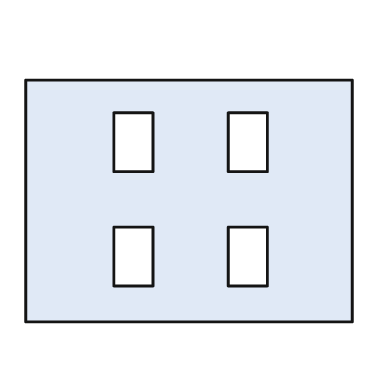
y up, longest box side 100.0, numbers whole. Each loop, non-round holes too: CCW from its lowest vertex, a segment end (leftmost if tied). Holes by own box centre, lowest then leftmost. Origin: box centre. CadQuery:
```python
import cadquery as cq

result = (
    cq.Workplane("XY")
    .moveTo(-50.0, -37.0)
    .lineTo(50.0, -37.0)
    .lineTo(50.0, 37.0)
    .lineTo(-50.0, 37.0)
    .close()
    .moveTo(-23.0, -26.0)
    .lineTo(-11.0, -26.0)
    .lineTo(-11.0, -8.0)
    .lineTo(-23.0, -8.0)
    .close()
    .moveTo(12.0, -26.0)
    .lineTo(24.0, -26.0)
    .lineTo(24.0, -8.0)
    .lineTo(12.0, -8.0)
    .close()
    .moveTo(-23.0, 9.0)
    .lineTo(-11.0, 9.0)
    .lineTo(-11.0, 27.0)
    .lineTo(-23.0, 27.0)
    .close()
    .moveTo(12.0, 9.0)
    .lineTo(24.0, 9.0)
    .lineTo(24.0, 27.0)
    .lineTo(12.0, 27.0)
    .close()
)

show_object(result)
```